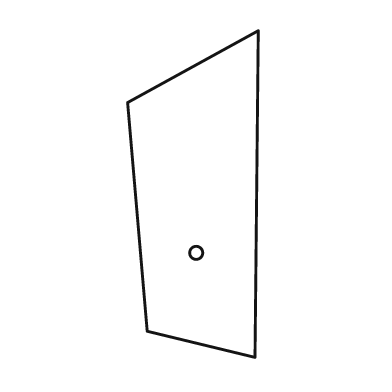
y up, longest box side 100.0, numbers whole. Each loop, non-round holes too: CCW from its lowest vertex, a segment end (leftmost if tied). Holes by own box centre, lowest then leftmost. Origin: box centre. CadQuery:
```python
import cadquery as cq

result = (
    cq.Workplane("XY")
    .moveTo(19.0, -50.0)
    .lineTo(20.0, 50.0)
    .lineTo(-20.0, 28.0)
    .lineTo(-14.0, -42.0)
    .close()
    .moveTo(1.0, -18.0)
    .circle(2.0)
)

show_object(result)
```